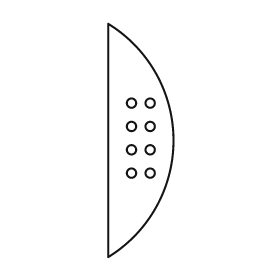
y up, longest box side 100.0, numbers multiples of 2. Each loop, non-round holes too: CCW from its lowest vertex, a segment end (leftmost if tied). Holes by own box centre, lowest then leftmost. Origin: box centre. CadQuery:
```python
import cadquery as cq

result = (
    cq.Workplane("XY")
    .moveTo(-14.0, -50.0)
    .threePointArc((14.0, 0.0), (-14.0, 50.0))
    .close()
    .moveTo(-4.0, -14.0)
    .circle(2.0)
    .moveTo(4.0, -14.0)
    .circle(2.0)
    .moveTo(-4.0, -4.0)
    .circle(2.0)
    .moveTo(4.0, -4.0)
    .circle(2.0)
    .moveTo(-4.0, 6.0)
    .circle(2.0)
    .moveTo(4.0, 6.0)
    .circle(2.0)
    .moveTo(-4.0, 16.0)
    .circle(2.0)
    .moveTo(4.0, 16.0)
    .circle(2.0)
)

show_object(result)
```